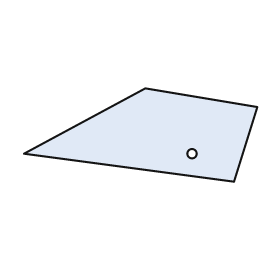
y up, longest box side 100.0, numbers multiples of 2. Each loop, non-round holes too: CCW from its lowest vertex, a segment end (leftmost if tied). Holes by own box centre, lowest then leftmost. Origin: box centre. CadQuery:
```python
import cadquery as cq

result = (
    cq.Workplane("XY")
    .moveTo(40.0, -20.0)
    .lineTo(50.0, 12.0)
    .lineTo(2.0, 20.0)
    .lineTo(-50.0, -8.0)
    .close()
    .moveTo(22.0, -8.0)
    .circle(2.0)
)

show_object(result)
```